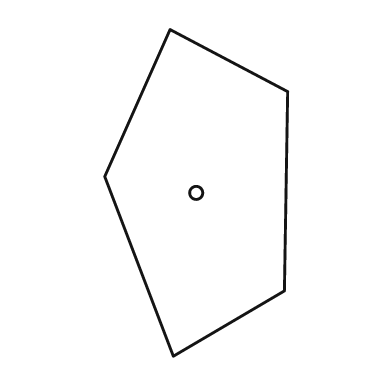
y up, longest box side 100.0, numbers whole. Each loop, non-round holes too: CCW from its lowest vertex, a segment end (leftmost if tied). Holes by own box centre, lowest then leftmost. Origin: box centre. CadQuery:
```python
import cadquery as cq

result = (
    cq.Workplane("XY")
    .moveTo(-7.0, -50.0)
    .lineTo(27.0, -30.0)
    .lineTo(28.0, 31.0)
    .lineTo(-8.0, 50.0)
    .lineTo(-28.0, 5.0)
    .close()
    .moveTo(0.0, 0.0)
    .circle(2.0)
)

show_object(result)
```